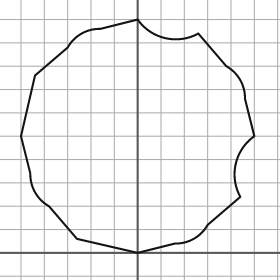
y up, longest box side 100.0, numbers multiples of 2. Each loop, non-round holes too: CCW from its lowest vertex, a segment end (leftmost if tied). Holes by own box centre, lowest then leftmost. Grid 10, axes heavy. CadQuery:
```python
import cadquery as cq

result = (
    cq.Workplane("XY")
    .moveTo(0.0, 0.0)
    .lineTo(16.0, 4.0)
    .threePointArc((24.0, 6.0), (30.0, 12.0))
    .lineTo(44.0, 24.0)
    .threePointArc((42.0, 38.0), (50.0, 50.0))
    .lineTo(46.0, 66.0)
    .threePointArc((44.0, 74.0), (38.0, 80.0))
    .lineTo(26.0, 94.0)
    .threePointArc((12.0, 92.0), (0.0, 100.0))
    .lineTo(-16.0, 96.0)
    .threePointArc((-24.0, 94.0), (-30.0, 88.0))
    .lineTo(-44.0, 76.0)
    .lineTo(-50.0, 50.0)
    .lineTo(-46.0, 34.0)
    .threePointArc((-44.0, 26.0), (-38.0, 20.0))
    .lineTo(-26.0, 6.0)
    .close()
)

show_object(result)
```